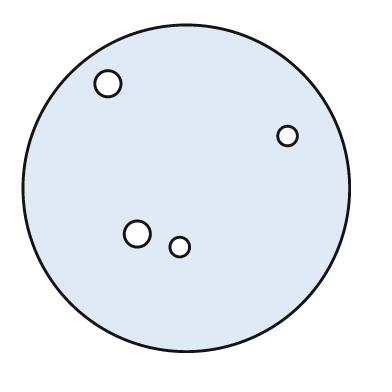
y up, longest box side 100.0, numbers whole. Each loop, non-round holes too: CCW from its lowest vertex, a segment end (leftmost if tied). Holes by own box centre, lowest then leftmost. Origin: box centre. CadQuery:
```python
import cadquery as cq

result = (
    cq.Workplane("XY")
    .moveTo(0.0, 0.0)
    .circle(50.0)
    .moveTo(-2.0, -18.0)
    .circle(3.0)
    .moveTo(-15.0, -14.0)
    .circle(4.0)
    .moveTo(31.0, 16.0)
    .circle(3.0)
    .moveTo(-24.0, 32.0)
    .circle(4.0)
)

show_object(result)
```